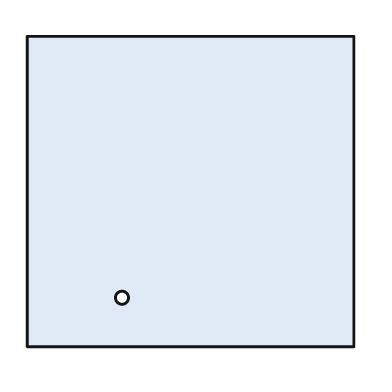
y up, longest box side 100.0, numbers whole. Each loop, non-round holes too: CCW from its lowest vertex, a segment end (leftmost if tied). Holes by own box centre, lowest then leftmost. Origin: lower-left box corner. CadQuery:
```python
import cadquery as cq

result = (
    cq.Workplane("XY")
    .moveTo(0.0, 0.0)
    .lineTo(100.0, 0.0)
    .lineTo(100.0, 95.0)
    .lineTo(0.0, 95.0)
    .close()
    .moveTo(29.0, 15.0)
    .circle(2.0)
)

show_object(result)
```